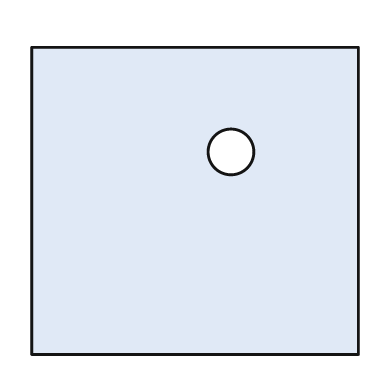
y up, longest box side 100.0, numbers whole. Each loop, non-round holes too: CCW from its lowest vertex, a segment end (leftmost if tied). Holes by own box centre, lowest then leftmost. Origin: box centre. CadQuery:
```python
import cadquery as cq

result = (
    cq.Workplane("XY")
    .moveTo(-50.0, -47.0)
    .lineTo(50.0, -47.0)
    .lineTo(50.0, 47.0)
    .lineTo(-50.0, 47.0)
    .close()
    .moveTo(11.0, 15.0)
    .circle(7.0)
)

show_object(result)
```